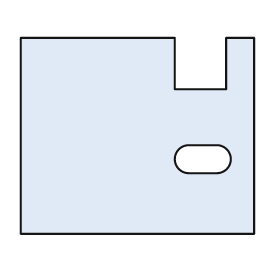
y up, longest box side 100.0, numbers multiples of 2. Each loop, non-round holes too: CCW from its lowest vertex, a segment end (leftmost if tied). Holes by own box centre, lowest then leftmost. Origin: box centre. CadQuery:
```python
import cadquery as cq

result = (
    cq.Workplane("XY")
    .moveTo(-50.0, -42.0)
    .lineTo(50.0, -42.0)
    .lineTo(50.0, 42.0)
    .lineTo(38.0, 42.0)
    .lineTo(38.0, 20.0)
    .lineTo(16.0, 20.0)
    .lineTo(16.0, 42.0)
    .lineTo(-50.0, 42.0)
    .close()
    .moveTo(22.0, -16.0)
    .lineTo(34.0, -16.0)
    .threePointArc((40.0, -10.0), (34.0, -4.0))
    .lineTo(22.0, -4.0)
    .threePointArc((16.0, -10.0), (22.0, -16.0))
    .close()
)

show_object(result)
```